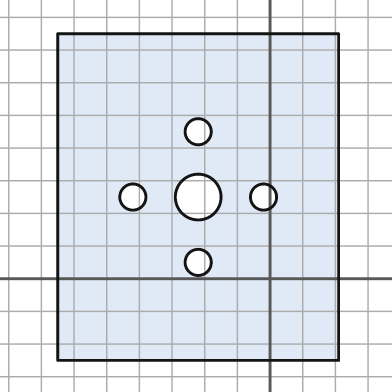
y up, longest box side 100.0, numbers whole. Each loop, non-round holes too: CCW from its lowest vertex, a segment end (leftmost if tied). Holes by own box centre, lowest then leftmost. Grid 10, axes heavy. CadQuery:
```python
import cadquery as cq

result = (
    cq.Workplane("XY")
    .moveTo(-65.0, -25.0)
    .lineTo(21.0, -25.0)
    .lineTo(21.0, 75.0)
    .lineTo(-65.0, 75.0)
    .close()
    .moveTo(-22.0, 5.0)
    .circle(4.0)
    .moveTo(-42.0, 25.0)
    .circle(4.0)
    .moveTo(-22.0, 25.0)
    .circle(7.0)
    .moveTo(-2.0, 25.0)
    .circle(4.0)
    .moveTo(-22.0, 45.0)
    .circle(4.0)
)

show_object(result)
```